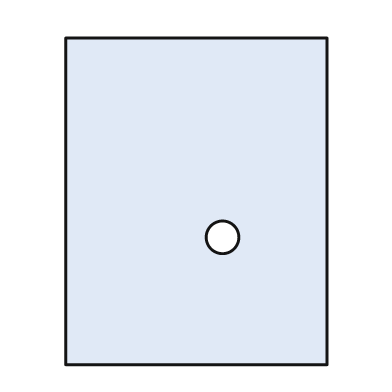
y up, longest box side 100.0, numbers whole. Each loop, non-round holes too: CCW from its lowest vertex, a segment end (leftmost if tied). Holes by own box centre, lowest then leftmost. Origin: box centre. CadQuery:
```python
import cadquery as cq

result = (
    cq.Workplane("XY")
    .moveTo(-40.0, -50.0)
    .lineTo(40.0, -50.0)
    .lineTo(40.0, 50.0)
    .lineTo(-40.0, 50.0)
    .close()
    .moveTo(8.0, -11.0)
    .circle(5.0)
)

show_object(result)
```